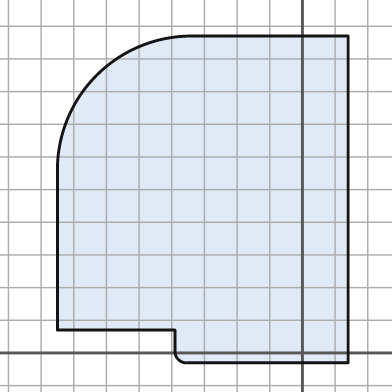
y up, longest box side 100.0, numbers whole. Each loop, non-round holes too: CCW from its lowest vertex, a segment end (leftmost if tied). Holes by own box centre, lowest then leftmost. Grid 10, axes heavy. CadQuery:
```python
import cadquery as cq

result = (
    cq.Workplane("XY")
    .moveTo(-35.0, -3.0)
    .lineTo(14.0, -3.0)
    .lineTo(14.0, 97.0)
    .lineTo(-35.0, 97.0)
    .threePointArc((-63.0, 85.0), (-75.0, 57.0))
    .lineTo(-75.0, 7.0)
    .lineTo(-39.0, 7.0)
    .lineTo(-39.0, 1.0)
    .threePointArc((-38.0, -2.0), (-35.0, -3.0))
    .close()
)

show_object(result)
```